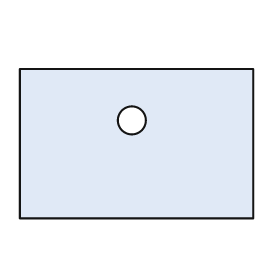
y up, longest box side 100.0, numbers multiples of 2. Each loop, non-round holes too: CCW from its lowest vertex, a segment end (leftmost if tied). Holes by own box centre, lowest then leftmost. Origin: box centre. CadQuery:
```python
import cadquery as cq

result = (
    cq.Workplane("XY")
    .moveTo(-50.0, -32.0)
    .lineTo(50.0, -32.0)
    .lineTo(50.0, 32.0)
    .lineTo(-50.0, 32.0)
    .close()
    .moveTo(-2.0, 10.0)
    .circle(6.0)
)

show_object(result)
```